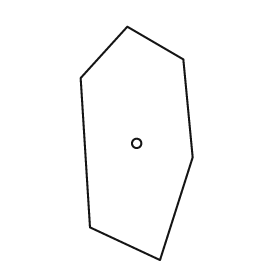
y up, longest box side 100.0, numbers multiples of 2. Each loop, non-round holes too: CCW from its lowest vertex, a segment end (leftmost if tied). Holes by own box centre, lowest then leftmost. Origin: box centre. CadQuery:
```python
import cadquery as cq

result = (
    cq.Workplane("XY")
    .moveTo(10.0, -50.0)
    .lineTo(24.0, -6.0)
    .lineTo(20.0, 36.0)
    .lineTo(-4.0, 50.0)
    .lineTo(-24.0, 28.0)
    .lineTo(-20.0, -36.0)
    .close()
    .moveTo(0.0, 0.0)
    .circle(2.0)
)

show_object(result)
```